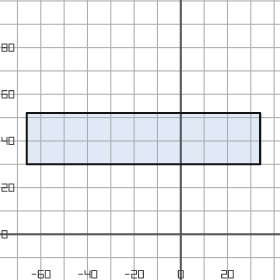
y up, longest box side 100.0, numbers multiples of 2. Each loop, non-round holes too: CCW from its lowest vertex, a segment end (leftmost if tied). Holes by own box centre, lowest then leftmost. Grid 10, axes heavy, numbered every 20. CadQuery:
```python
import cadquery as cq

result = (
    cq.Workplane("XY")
    .moveTo(-66.0, 30.0)
    .lineTo(34.0, 30.0)
    .lineTo(34.0, 52.0)
    .lineTo(-66.0, 52.0)
    .close()
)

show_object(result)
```